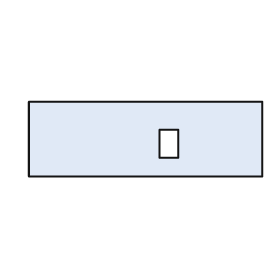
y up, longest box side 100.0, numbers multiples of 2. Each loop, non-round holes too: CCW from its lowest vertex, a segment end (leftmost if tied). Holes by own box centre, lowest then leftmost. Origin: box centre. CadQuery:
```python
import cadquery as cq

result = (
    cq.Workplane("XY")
    .moveTo(-50.0, -16.0)
    .lineTo(50.0, -16.0)
    .lineTo(50.0, 16.0)
    .lineTo(-50.0, 16.0)
    .close()
    .moveTo(6.0, -8.0)
    .lineTo(14.0, -8.0)
    .lineTo(14.0, 4.0)
    .lineTo(6.0, 4.0)
    .close()
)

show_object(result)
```